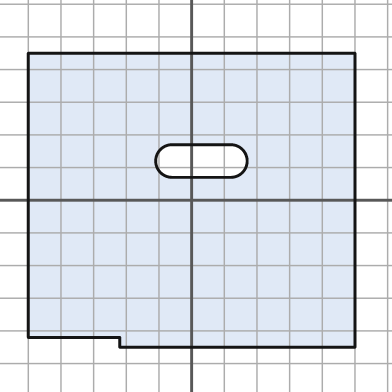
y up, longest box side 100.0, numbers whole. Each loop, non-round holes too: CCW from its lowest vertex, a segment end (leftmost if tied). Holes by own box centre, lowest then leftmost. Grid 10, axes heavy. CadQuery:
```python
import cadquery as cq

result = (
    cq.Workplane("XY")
    .moveTo(-22.0, -45.0)
    .lineTo(50.0, -45.0)
    .lineTo(50.0, 45.0)
    .lineTo(-50.0, 45.0)
    .lineTo(-50.0, -42.0)
    .lineTo(-22.0, -42.0)
    .close()
    .moveTo(-6.0, 7.0)
    .lineTo(12.0, 7.0)
    .threePointArc((17.0, 12.0), (12.0, 17.0))
    .lineTo(-6.0, 17.0)
    .threePointArc((-11.0, 12.0), (-6.0, 7.0))
    .close()
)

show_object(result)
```